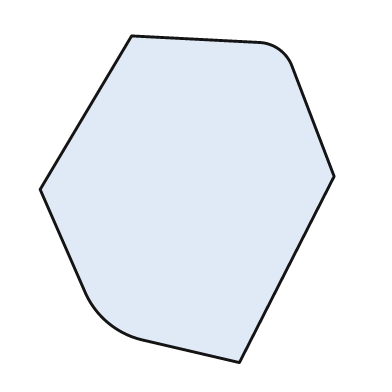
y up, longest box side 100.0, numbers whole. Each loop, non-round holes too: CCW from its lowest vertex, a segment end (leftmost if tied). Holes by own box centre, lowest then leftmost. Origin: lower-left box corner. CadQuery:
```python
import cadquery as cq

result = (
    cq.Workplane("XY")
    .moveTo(61.0, 0.0)
    .lineTo(90.0, 57.0)
    .lineTo(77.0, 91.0)
    .threePointArc((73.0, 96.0), (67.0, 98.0))
    .lineTo(28.0, 100.0)
    .lineTo(0.0, 53.0)
    .lineTo(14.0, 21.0)
    .threePointArc((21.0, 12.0), (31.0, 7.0))
    .close()
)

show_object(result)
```